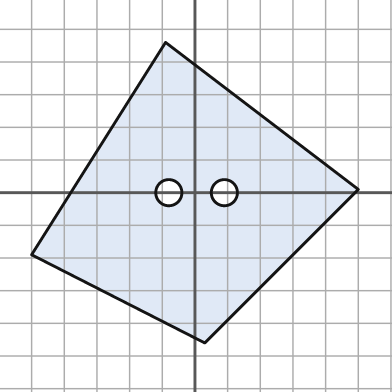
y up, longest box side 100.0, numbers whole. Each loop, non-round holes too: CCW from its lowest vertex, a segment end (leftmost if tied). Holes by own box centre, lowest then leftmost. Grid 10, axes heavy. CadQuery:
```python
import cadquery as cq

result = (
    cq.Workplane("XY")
    .moveTo(3.0, -46.0)
    .lineTo(50.0, 1.0)
    .lineTo(-9.0, 46.0)
    .lineTo(-50.0, -19.0)
    .close()
    .moveTo(-8.0, 0.0)
    .circle(4.0)
    .moveTo(9.0, 0.0)
    .circle(4.0)
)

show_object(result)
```